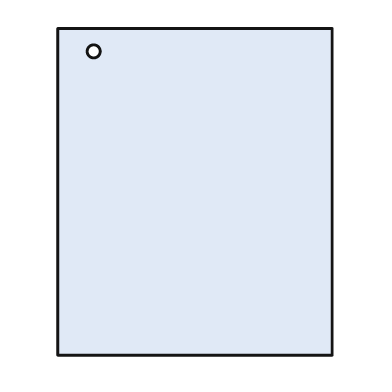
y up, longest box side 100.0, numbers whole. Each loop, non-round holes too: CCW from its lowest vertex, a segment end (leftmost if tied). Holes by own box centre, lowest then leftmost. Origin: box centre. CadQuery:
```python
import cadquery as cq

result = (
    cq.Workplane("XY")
    .moveTo(-42.0, -50.0)
    .lineTo(42.0, -50.0)
    .lineTo(42.0, 50.0)
    .lineTo(-42.0, 50.0)
    .close()
    .moveTo(-31.0, 43.0)
    .circle(2.0)
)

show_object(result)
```